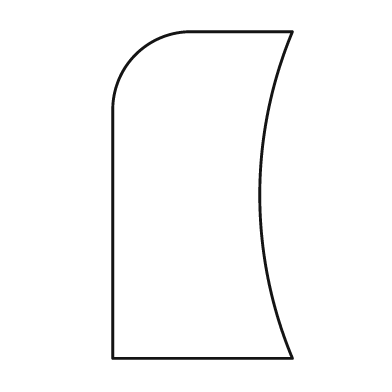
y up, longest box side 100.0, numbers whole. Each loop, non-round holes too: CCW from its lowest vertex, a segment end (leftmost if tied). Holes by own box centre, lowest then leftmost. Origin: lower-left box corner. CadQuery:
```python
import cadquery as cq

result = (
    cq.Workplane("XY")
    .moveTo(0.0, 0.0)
    .lineTo(55.0, 0.0)
    .threePointArc((45.0, 50.0), (55.0, 100.0))
    .lineTo(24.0, 100.0)
    .threePointArc((7.0, 93.0), (0.0, 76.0))
    .close()
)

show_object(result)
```